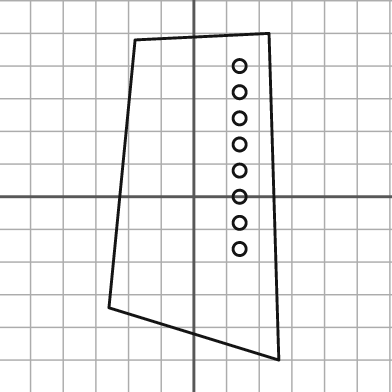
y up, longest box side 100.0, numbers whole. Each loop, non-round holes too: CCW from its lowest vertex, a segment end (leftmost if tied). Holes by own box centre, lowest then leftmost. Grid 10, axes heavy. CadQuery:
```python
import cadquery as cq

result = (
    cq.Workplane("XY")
    .moveTo(26.0, -50.0)
    .lineTo(23.0, 50.0)
    .lineTo(-18.0, 48.0)
    .lineTo(-26.0, -34.0)
    .close()
    .moveTo(14.0, -16.0)
    .circle(2.0)
    .moveTo(14.0, -8.0)
    .circle(2.0)
    .moveTo(14.0, 0.0)
    .circle(2.0)
    .moveTo(14.0, 8.0)
    .circle(2.0)
    .moveTo(14.0, 16.0)
    .circle(2.0)
    .moveTo(14.0, 24.0)
    .circle(2.0)
    .moveTo(14.0, 32.0)
    .circle(2.0)
    .moveTo(14.0, 40.0)
    .circle(2.0)
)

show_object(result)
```